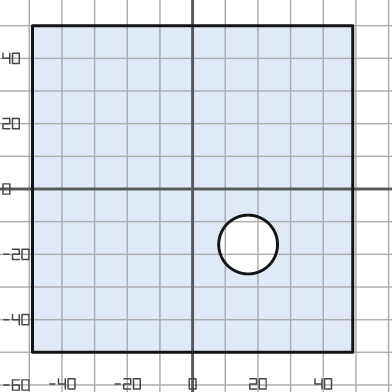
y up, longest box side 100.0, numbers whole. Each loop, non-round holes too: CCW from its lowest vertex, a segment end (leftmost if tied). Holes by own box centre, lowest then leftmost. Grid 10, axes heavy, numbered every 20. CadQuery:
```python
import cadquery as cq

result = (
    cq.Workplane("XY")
    .moveTo(-49.0, -50.0)
    .lineTo(49.0, -50.0)
    .lineTo(49.0, 50.0)
    .lineTo(-49.0, 50.0)
    .close()
    .moveTo(17.0, -17.0)
    .circle(9.0)
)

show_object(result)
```